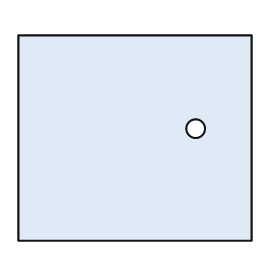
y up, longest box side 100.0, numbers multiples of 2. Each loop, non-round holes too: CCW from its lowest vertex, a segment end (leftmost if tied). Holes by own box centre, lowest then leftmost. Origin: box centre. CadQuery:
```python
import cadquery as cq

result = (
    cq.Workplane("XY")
    .moveTo(-50.0, -44.0)
    .lineTo(50.0, -44.0)
    .lineTo(50.0, 44.0)
    .lineTo(-50.0, 44.0)
    .close()
    .moveTo(26.0, 4.0)
    .circle(4.0)
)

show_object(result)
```